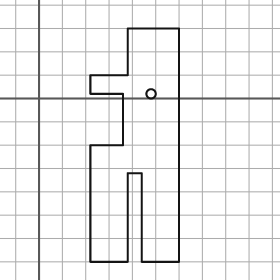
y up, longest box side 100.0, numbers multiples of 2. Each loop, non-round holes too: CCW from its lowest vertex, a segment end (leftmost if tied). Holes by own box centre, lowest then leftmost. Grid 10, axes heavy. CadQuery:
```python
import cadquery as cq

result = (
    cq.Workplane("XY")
    .moveTo(22.0, -70.0)
    .lineTo(38.0, -70.0)
    .lineTo(38.0, -32.0)
    .lineTo(44.0, -32.0)
    .lineTo(44.0, -70.0)
    .lineTo(60.0, -70.0)
    .lineTo(60.0, 30.0)
    .lineTo(38.0, 30.0)
    .lineTo(38.0, 10.0)
    .lineTo(22.0, 10.0)
    .lineTo(22.0, 2.0)
    .lineTo(36.0, 2.0)
    .lineTo(36.0, -20.0)
    .lineTo(22.0, -20.0)
    .close()
    .moveTo(48.0, 2.0)
    .circle(2.0)
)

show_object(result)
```